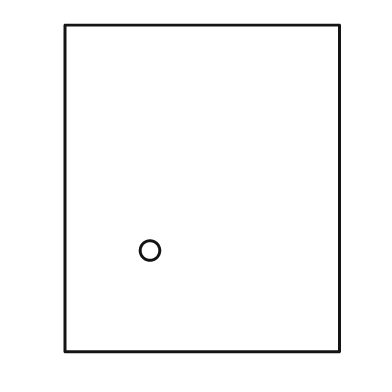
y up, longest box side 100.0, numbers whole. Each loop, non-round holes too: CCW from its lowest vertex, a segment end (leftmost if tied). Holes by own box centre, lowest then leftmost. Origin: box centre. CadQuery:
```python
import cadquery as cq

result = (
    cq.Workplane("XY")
    .moveTo(-42.0, -50.0)
    .lineTo(42.0, -50.0)
    .lineTo(42.0, 50.0)
    .lineTo(-42.0, 50.0)
    .close()
    .moveTo(-16.0, -19.0)
    .circle(3.0)
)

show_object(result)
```